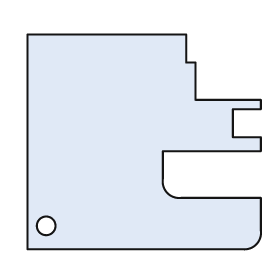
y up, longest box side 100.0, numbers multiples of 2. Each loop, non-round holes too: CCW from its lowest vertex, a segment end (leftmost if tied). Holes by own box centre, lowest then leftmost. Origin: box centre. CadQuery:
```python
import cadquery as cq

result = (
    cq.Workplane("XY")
    .moveTo(-50.0, -46.0)
    .lineTo(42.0, -46.0)
    .threePointArc((48.0, -44.0), (50.0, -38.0))
    .lineTo(50.0, -24.0)
    .lineTo(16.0, -24.0)
    .threePointArc((10.0, -22.0), (8.0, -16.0))
    .lineTo(8.0, -4.0)
    .lineTo(50.0, -4.0)
    .lineTo(50.0, 2.0)
    .lineTo(38.0, 2.0)
    .lineTo(38.0, 14.0)
    .lineTo(50.0, 14.0)
    .lineTo(50.0, 18.0)
    .lineTo(22.0, 18.0)
    .lineTo(22.0, 34.0)
    .lineTo(18.0, 34.0)
    .lineTo(18.0, 46.0)
    .lineTo(-50.0, 46.0)
    .close()
    .moveTo(-42.0, -36.0)
    .circle(4.0)
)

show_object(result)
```